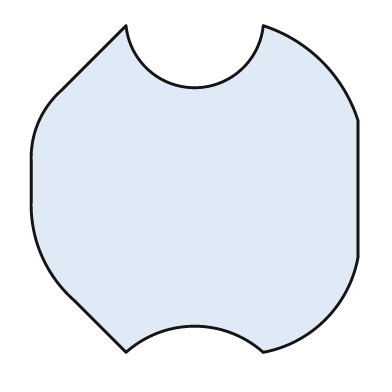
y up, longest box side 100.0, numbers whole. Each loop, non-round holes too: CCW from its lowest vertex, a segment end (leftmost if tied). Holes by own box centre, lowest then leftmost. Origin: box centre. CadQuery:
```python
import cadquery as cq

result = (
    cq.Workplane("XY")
    .moveTo(-21.0, -50.0)
    .threePointArc((0.0, -42.0), (21.0, -50.0))
    .threePointArc((40.0, -40.0), (50.0, -21.0))
    .lineTo(50.0, 21.0)
    .threePointArc((39.0, 39.0), (21.0, 50.0))
    .threePointArc((0.0, 31.0), (-21.0, 50.0))
    .lineTo(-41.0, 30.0)
    .threePointArc((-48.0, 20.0), (-50.0, 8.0))
    .lineTo(-50.0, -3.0)
    .threePointArc((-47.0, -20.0), (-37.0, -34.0))
    .close()
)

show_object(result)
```